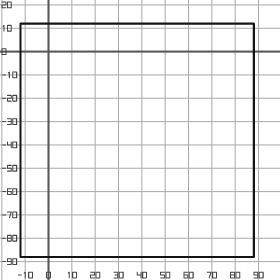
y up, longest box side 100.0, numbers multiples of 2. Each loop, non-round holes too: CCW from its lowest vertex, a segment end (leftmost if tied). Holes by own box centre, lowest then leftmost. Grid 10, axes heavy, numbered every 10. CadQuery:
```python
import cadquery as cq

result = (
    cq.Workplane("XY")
    .moveTo(-12.0, -88.0)
    .lineTo(88.0, -88.0)
    .lineTo(88.0, 12.0)
    .lineTo(-12.0, 12.0)
    .close()
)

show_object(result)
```